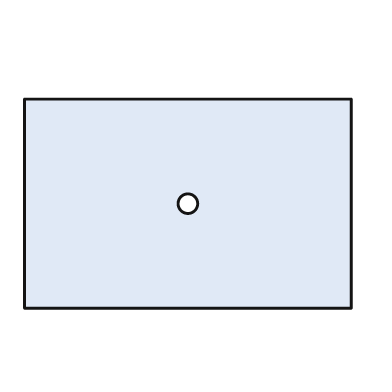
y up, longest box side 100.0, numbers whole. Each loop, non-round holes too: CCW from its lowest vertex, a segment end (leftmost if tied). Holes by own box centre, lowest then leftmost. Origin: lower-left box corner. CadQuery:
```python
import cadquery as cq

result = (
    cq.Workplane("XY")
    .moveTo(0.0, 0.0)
    .lineTo(100.0, 0.0)
    .lineTo(100.0, 64.0)
    .lineTo(0.0, 64.0)
    .close()
    .moveTo(50.0, 32.0)
    .circle(3.0)
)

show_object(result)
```